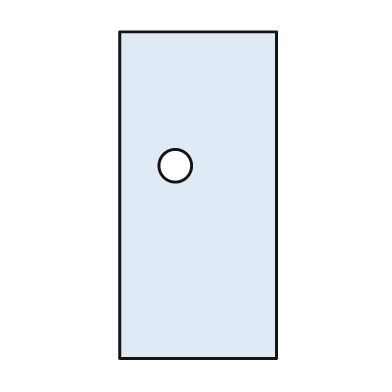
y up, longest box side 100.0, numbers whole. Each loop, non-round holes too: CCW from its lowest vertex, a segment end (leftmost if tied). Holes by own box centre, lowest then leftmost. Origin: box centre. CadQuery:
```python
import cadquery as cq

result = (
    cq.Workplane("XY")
    .moveTo(-24.0, -50.0)
    .lineTo(24.0, -50.0)
    .lineTo(24.0, 50.0)
    .lineTo(-24.0, 50.0)
    .close()
    .moveTo(-7.0, 9.0)
    .circle(5.0)
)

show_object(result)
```